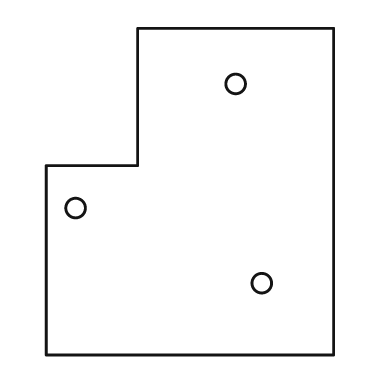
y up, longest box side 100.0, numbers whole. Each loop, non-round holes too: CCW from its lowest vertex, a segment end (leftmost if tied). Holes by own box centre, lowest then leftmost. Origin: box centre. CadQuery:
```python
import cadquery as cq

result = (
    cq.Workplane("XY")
    .moveTo(-44.0, -50.0)
    .lineTo(44.0, -50.0)
    .lineTo(44.0, 50.0)
    .lineTo(-16.0, 50.0)
    .lineTo(-16.0, 8.0)
    .lineTo(-44.0, 8.0)
    .close()
    .moveTo(22.0, -28.0)
    .circle(3.0)
    .moveTo(-35.0, -5.0)
    .circle(3.0)
    .moveTo(14.0, 33.0)
    .circle(3.0)
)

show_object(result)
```